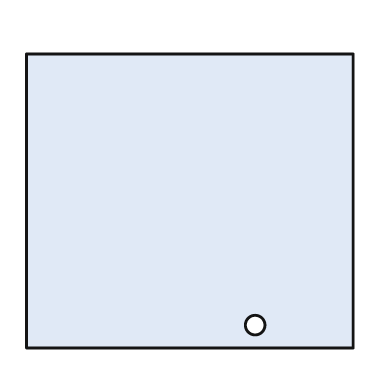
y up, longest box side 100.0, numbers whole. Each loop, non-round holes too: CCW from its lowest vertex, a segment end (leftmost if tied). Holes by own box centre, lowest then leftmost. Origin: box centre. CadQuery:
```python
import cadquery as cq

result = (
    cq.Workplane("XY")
    .moveTo(-50.0, -45.0)
    .lineTo(50.0, -45.0)
    .lineTo(50.0, 45.0)
    .lineTo(-50.0, 45.0)
    .close()
    .moveTo(20.0, -38.0)
    .circle(3.0)
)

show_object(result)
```